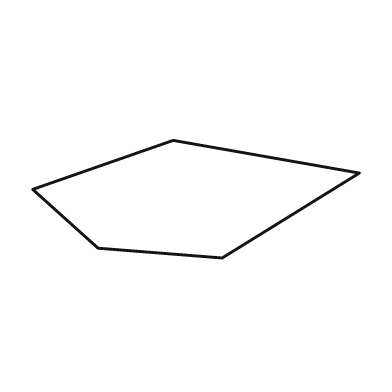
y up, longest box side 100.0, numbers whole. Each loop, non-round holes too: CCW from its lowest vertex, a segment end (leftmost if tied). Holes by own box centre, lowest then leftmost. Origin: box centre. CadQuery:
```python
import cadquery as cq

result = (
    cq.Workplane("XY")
    .moveTo(8.0, -18.0)
    .lineTo(50.0, 8.0)
    .lineTo(-7.0, 18.0)
    .lineTo(-50.0, 3.0)
    .lineTo(-30.0, -15.0)
    .close()
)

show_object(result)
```